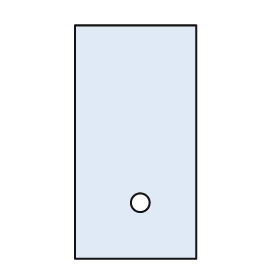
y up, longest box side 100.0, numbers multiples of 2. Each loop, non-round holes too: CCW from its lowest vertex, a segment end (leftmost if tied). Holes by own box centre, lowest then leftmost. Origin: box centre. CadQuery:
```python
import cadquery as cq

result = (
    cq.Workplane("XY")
    .moveTo(-26.0, -50.0)
    .lineTo(26.0, -50.0)
    .lineTo(26.0, 50.0)
    .lineTo(-26.0, 50.0)
    .close()
    .moveTo(2.0, -26.0)
    .circle(4.0)
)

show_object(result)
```